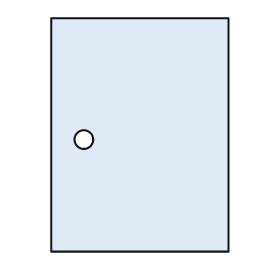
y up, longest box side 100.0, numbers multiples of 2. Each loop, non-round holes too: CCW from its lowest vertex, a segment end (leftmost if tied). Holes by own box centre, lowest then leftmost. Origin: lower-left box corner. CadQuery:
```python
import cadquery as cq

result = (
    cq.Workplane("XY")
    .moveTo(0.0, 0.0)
    .lineTo(76.0, 0.0)
    .lineTo(76.0, 100.0)
    .lineTo(0.0, 100.0)
    .close()
    .moveTo(14.0, 48.0)
    .circle(4.0)
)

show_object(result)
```